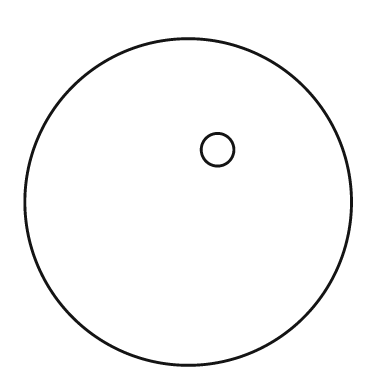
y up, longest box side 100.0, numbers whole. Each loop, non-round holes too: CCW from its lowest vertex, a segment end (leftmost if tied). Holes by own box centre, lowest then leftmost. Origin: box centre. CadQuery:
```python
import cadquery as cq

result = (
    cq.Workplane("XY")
    .moveTo(0.0, 0.0)
    .circle(50.0)
    .moveTo(9.0, 16.0)
    .circle(5.0)
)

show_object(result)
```